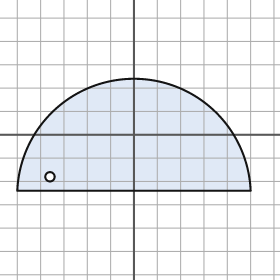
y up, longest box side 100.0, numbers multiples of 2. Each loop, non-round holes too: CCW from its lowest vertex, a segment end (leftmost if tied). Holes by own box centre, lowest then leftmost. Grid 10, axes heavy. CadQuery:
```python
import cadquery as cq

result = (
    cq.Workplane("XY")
    .moveTo(-50.0, -24.0)
    .lineTo(50.0, -24.0)
    .threePointArc((0.0, 24.0), (-50.0, -24.0))
    .close()
    .moveTo(-36.0, -18.0)
    .circle(2.0)
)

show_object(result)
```